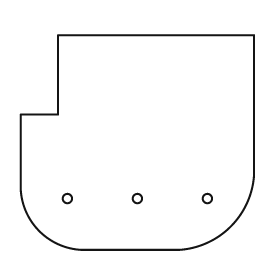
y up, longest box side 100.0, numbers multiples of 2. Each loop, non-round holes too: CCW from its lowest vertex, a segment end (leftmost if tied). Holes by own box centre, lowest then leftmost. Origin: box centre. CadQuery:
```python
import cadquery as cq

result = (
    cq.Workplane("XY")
    .moveTo(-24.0, -46.0)
    .lineTo(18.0, -46.0)
    .threePointArc((40.0, -36.0), (50.0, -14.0))
    .lineTo(50.0, 46.0)
    .lineTo(-34.0, 46.0)
    .lineTo(-34.0, 12.0)
    .lineTo(-50.0, 12.0)
    .lineTo(-50.0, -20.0)
    .threePointArc((-42.0, -38.0), (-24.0, -46.0))
    .close()
    .moveTo(-30.0, -24.0)
    .circle(2.0)
    .moveTo(0.0, -24.0)
    .circle(2.0)
    .moveTo(30.0, -24.0)
    .circle(2.0)
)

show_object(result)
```